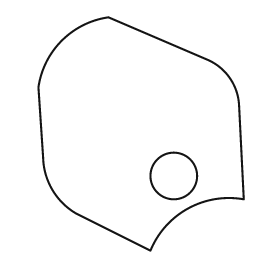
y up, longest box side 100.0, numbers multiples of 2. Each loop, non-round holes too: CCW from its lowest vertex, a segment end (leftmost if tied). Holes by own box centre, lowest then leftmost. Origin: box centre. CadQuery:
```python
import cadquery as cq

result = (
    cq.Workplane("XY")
    .moveTo(4.0, -50.0)
    .threePointArc((20.0, -32.0), (44.0, -28.0))
    .lineTo(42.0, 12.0)
    .threePointArc((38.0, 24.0), (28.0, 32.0))
    .lineTo(-14.0, 50.0)
    .threePointArc((-34.0, 40.0), (-44.0, 20.0))
    .lineTo(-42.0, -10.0)
    .threePointArc((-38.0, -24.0), (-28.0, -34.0))
    .close()
    .moveTo(14.0, -18.0)
    .circle(10.0)
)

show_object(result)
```